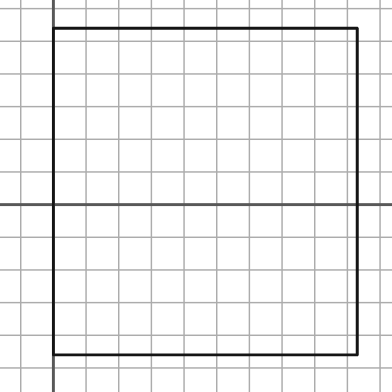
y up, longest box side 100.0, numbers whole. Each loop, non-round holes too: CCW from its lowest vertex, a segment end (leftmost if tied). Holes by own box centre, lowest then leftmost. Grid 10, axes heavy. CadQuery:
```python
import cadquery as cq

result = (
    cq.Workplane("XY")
    .moveTo(0.0, -46.0)
    .lineTo(93.0, -46.0)
    .lineTo(93.0, 54.0)
    .lineTo(0.0, 54.0)
    .close()
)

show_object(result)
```